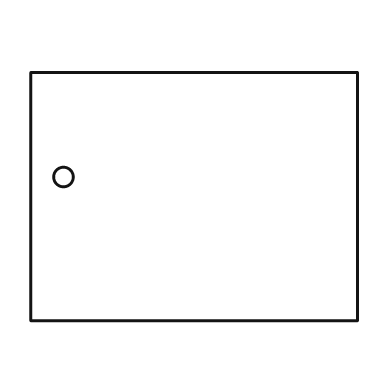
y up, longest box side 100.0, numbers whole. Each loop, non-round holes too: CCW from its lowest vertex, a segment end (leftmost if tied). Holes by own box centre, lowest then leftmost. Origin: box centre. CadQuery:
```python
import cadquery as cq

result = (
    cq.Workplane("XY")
    .moveTo(-50.0, -38.0)
    .lineTo(50.0, -38.0)
    .lineTo(50.0, 38.0)
    .lineTo(-50.0, 38.0)
    .close()
    .moveTo(-40.0, 6.0)
    .circle(3.0)
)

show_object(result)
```